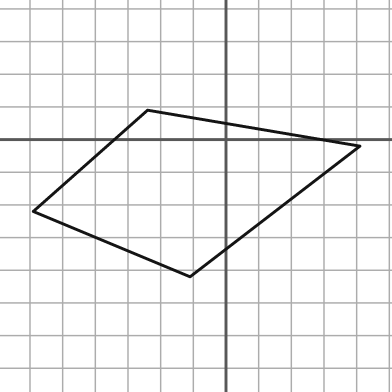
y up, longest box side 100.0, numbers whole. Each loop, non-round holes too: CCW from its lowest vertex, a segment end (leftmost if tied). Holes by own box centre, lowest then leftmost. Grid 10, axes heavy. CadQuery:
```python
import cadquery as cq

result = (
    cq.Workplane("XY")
    .moveTo(-11.0, -42.0)
    .lineTo(41.0, -2.0)
    .lineTo(-24.0, 9.0)
    .lineTo(-59.0, -22.0)
    .close()
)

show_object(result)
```